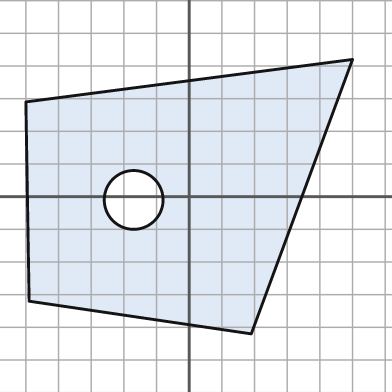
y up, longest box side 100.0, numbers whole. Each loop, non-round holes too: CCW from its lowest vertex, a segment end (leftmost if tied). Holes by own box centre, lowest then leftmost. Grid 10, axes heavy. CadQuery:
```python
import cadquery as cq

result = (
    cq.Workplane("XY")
    .moveTo(19.0, -42.0)
    .lineTo(50.0, 42.0)
    .lineTo(-50.0, 29.0)
    .lineTo(-49.0, -32.0)
    .close()
    .moveTo(-17.0, -1.0)
    .circle(9.0)
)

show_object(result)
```